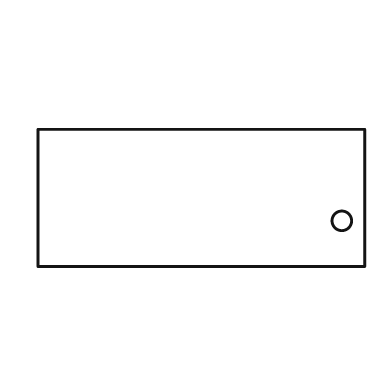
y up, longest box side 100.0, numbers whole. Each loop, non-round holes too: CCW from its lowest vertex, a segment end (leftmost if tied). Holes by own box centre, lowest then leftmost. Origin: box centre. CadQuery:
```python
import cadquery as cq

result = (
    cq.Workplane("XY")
    .moveTo(-50.0, -21.0)
    .lineTo(50.0, -21.0)
    .lineTo(50.0, 21.0)
    .lineTo(-50.0, 21.0)
    .close()
    .moveTo(43.0, -7.0)
    .circle(3.0)
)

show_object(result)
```